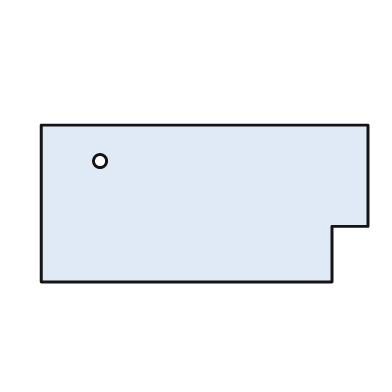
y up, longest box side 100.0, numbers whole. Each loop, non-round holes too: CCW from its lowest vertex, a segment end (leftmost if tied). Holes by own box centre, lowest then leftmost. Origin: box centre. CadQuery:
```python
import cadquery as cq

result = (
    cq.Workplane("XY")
    .moveTo(-50.0, -24.0)
    .lineTo(39.0, -24.0)
    .lineTo(39.0, -7.0)
    .lineTo(50.0, -7.0)
    .lineTo(50.0, 24.0)
    .lineTo(-50.0, 24.0)
    .close()
    .moveTo(-32.0, 13.0)
    .circle(2.0)
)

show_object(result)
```